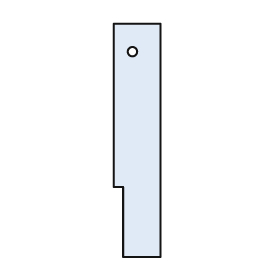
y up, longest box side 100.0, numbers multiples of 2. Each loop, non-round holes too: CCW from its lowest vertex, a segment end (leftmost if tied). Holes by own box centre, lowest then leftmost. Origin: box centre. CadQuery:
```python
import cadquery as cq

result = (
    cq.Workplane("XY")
    .moveTo(-6.0, -50.0)
    .lineTo(10.0, -50.0)
    .lineTo(10.0, 50.0)
    .lineTo(-10.0, 50.0)
    .lineTo(-10.0, -20.0)
    .lineTo(-6.0, -20.0)
    .close()
    .moveTo(-2.0, 38.0)
    .circle(2.0)
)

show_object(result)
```